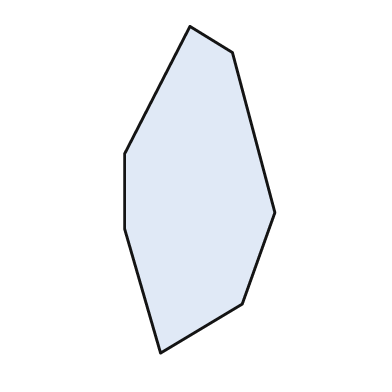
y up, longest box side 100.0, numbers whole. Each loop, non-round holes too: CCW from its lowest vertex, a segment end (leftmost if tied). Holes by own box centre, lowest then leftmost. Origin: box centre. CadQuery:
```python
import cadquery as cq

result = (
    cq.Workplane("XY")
    .moveTo(-12.0, -50.0)
    .lineTo(13.0, -35.0)
    .lineTo(23.0, -7.0)
    .lineTo(10.0, 42.0)
    .lineTo(-3.0, 50.0)
    .lineTo(-23.0, 11.0)
    .lineTo(-23.0, -12.0)
    .close()
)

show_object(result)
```